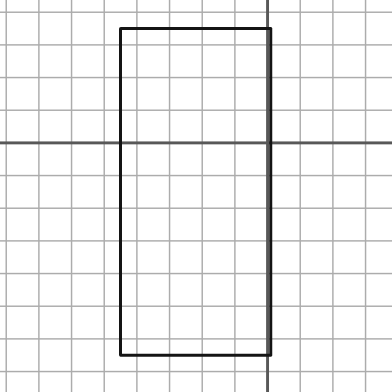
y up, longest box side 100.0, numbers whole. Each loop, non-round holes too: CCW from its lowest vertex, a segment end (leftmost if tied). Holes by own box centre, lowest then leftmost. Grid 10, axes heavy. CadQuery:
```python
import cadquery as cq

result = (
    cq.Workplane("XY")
    .moveTo(-45.0, -65.0)
    .lineTo(1.0, -65.0)
    .lineTo(1.0, 35.0)
    .lineTo(-45.0, 35.0)
    .close()
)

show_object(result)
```